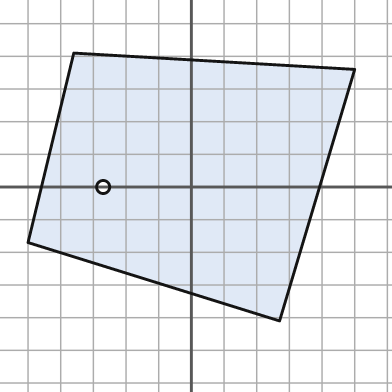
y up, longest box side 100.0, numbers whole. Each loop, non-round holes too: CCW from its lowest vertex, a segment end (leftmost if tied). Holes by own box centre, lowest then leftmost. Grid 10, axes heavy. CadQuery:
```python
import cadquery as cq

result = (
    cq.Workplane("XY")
    .moveTo(27.0, -41.0)
    .lineTo(50.0, 36.0)
    .lineTo(-36.0, 41.0)
    .lineTo(-50.0, -17.0)
    .close()
    .moveTo(-27.0, 0.0)
    .circle(2.0)
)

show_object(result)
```